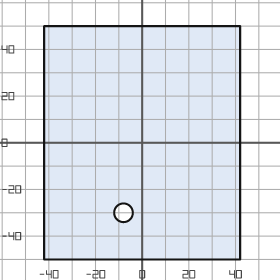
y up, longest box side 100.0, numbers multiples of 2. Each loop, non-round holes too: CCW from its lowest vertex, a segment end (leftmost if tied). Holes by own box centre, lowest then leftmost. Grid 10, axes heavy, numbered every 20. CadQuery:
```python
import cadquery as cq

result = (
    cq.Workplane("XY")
    .moveTo(-42.0, -50.0)
    .lineTo(42.0, -50.0)
    .lineTo(42.0, 50.0)
    .lineTo(-42.0, 50.0)
    .close()
    .moveTo(-8.0, -30.0)
    .circle(4.0)
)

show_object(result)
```